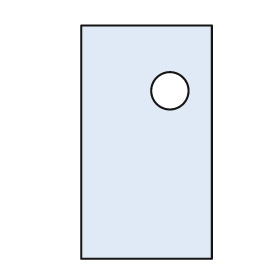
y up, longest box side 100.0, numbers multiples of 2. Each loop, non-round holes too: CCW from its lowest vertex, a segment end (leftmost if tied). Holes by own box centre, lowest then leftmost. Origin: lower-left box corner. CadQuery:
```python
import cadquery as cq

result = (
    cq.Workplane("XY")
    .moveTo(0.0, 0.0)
    .lineTo(56.0, 0.0)
    .lineTo(56.0, 100.0)
    .lineTo(0.0, 100.0)
    .close()
    .moveTo(38.0, 72.0)
    .circle(8.0)
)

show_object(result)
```